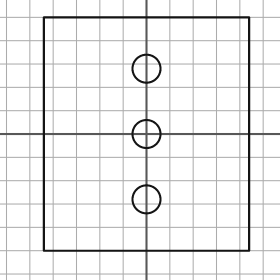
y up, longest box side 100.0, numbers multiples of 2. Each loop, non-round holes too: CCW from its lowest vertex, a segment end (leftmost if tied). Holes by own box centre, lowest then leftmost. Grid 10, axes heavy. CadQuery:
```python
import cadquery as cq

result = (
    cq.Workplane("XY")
    .moveTo(-44.0, -50.0)
    .lineTo(44.0, -50.0)
    .lineTo(44.0, 50.0)
    .lineTo(-44.0, 50.0)
    .close()
    .moveTo(0.0, -28.0)
    .circle(6.0)
    .moveTo(0.0, 0.0)
    .circle(6.0)
    .moveTo(0.0, 28.0)
    .circle(6.0)
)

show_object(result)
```